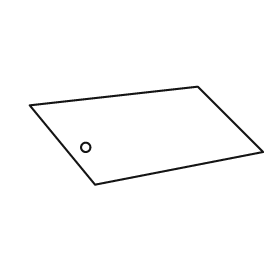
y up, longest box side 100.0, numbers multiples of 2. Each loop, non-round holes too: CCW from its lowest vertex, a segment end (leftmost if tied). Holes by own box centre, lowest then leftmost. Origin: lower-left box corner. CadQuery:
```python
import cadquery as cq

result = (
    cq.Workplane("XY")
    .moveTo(28.0, 0.0)
    .lineTo(100.0, 14.0)
    .lineTo(72.0, 42.0)
    .lineTo(0.0, 34.0)
    .close()
    .moveTo(24.0, 16.0)
    .circle(2.0)
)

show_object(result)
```